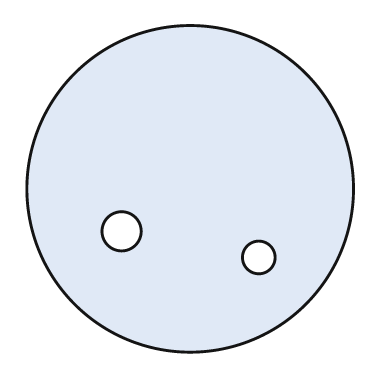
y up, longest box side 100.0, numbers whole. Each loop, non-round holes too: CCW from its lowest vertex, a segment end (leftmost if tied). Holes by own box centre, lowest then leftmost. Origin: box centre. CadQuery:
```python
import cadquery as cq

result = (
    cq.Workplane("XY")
    .moveTo(0.0, 0.0)
    .circle(50.0)
    .moveTo(21.0, -21.0)
    .circle(5.0)
    .moveTo(-21.0, -13.0)
    .circle(6.0)
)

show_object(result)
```